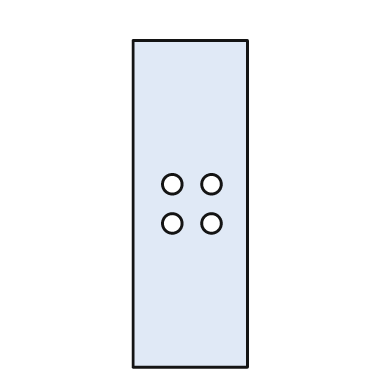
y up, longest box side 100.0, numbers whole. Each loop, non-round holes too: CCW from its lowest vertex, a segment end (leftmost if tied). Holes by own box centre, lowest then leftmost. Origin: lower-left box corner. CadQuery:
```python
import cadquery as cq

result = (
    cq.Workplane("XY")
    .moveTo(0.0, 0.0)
    .lineTo(35.0, 0.0)
    .lineTo(35.0, 100.0)
    .lineTo(0.0, 100.0)
    .close()
    .moveTo(12.0, 44.0)
    .circle(3.0)
    .moveTo(24.0, 44.0)
    .circle(3.0)
    .moveTo(12.0, 56.0)
    .circle(3.0)
    .moveTo(24.0, 56.0)
    .circle(3.0)
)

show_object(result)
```